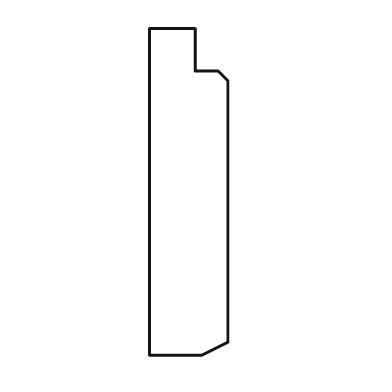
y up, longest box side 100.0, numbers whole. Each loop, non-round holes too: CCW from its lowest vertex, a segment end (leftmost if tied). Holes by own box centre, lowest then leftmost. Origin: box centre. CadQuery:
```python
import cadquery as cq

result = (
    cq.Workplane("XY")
    .moveTo(-12.0, -50.0)
    .lineTo(4.0, -50.0)
    .lineTo(12.0, -46.0)
    .lineTo(12.0, 34.0)
    .lineTo(9.0, 37.0)
    .lineTo(2.0, 37.0)
    .lineTo(2.0, 50.0)
    .lineTo(-12.0, 50.0)
    .close()
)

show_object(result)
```